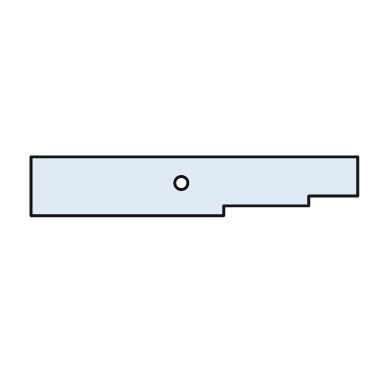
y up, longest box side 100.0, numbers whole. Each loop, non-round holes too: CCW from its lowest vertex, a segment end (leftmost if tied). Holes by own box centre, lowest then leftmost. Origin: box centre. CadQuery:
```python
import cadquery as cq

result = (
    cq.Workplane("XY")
    .moveTo(-50.0, -9.0)
    .lineTo(9.0, -9.0)
    .lineTo(9.0, -6.0)
    .lineTo(35.0, -6.0)
    .lineTo(35.0, -3.0)
    .lineTo(50.0, -3.0)
    .lineTo(50.0, 9.0)
    .lineTo(-50.0, 9.0)
    .close()
    .moveTo(-4.0, 1.0)
    .circle(2.0)
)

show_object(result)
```